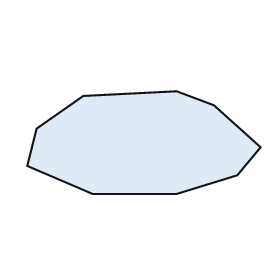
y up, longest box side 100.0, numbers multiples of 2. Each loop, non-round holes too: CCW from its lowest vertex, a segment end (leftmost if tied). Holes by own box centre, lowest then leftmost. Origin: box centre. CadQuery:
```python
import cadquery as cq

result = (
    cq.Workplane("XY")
    .moveTo(-22.0, -22.0)
    .lineTo(14.0, -22.0)
    .lineTo(40.0, -14.0)
    .lineTo(50.0, -2.0)
    .lineTo(30.0, 16.0)
    .lineTo(14.0, 22.0)
    .lineTo(-26.0, 20.0)
    .lineTo(-46.0, 6.0)
    .lineTo(-50.0, -10.0)
    .close()
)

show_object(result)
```